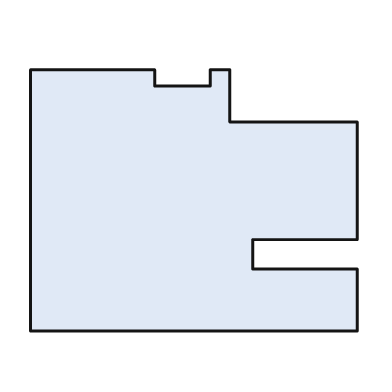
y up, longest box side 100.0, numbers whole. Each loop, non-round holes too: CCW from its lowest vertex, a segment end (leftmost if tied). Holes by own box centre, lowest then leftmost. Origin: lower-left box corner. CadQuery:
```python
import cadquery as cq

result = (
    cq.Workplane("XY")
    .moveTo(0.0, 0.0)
    .lineTo(100.0, 0.0)
    .lineTo(100.0, 19.0)
    .lineTo(68.0, 19.0)
    .lineTo(68.0, 28.0)
    .lineTo(100.0, 28.0)
    .lineTo(100.0, 64.0)
    .lineTo(61.0, 64.0)
    .lineTo(61.0, 80.0)
    .lineTo(55.0, 80.0)
    .lineTo(55.0, 75.0)
    .lineTo(38.0, 75.0)
    .lineTo(38.0, 80.0)
    .lineTo(0.0, 80.0)
    .close()
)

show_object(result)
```